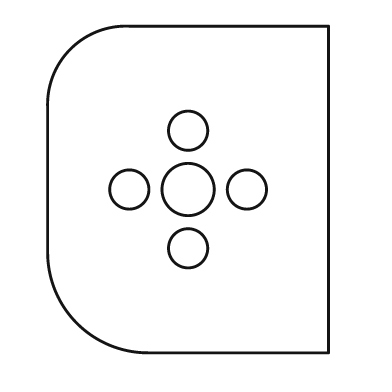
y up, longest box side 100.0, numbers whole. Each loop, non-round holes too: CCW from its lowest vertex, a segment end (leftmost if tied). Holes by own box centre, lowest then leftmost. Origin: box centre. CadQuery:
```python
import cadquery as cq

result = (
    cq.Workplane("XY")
    .moveTo(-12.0, -50.0)
    .lineTo(43.0, -50.0)
    .lineTo(43.0, 50.0)
    .lineTo(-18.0, 50.0)
    .threePointArc((-36.0, 43.0), (-43.0, 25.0))
    .lineTo(-43.0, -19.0)
    .threePointArc((-34.0, -41.0), (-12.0, -50.0))
    .close()
    .moveTo(0.0, -18.0)
    .circle(6.0)
    .moveTo(-18.0, 0.0)
    .circle(6.0)
    .moveTo(0.0, 0.0)
    .circle(8.0)
    .moveTo(18.0, 0.0)
    .circle(6.0)
    .moveTo(0.0, 18.0)
    .circle(6.0)
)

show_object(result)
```